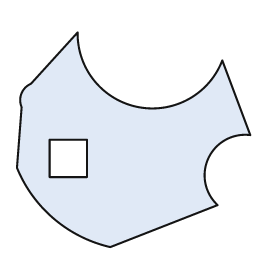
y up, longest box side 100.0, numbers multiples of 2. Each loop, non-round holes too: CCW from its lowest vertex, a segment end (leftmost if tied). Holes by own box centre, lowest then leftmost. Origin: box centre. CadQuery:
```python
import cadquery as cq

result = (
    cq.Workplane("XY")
    .moveTo(-10.0, -46.0)
    .lineTo(36.0, -28.0)
    .threePointArc((32.0, -8.0), (50.0, 2.0))
    .lineTo(38.0, 34.0)
    .threePointArc((2.0, 14.0), (-24.0, 46.0))
    .lineTo(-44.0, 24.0)
    .threePointArc((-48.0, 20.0), (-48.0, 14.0))
    .lineTo(-50.0, -12.0)
    .threePointArc((-34.0, -34.0), (-10.0, -46.0))
    .close()
    .moveTo(-36.0, -16.0)
    .lineTo(-20.0, -16.0)
    .lineTo(-20.0, 0.0)
    .lineTo(-36.0, 0.0)
    .close()
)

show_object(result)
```